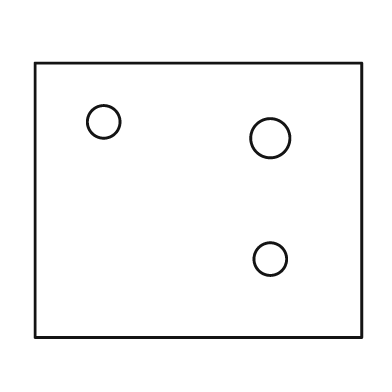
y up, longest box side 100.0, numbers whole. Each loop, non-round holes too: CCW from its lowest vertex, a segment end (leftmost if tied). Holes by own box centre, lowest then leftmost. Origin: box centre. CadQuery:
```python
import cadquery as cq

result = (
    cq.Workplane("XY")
    .moveTo(-50.0, -42.0)
    .lineTo(50.0, -42.0)
    .lineTo(50.0, 42.0)
    .lineTo(-50.0, 42.0)
    .close()
    .moveTo(22.0, -18.0)
    .circle(5.0)
    .moveTo(22.0, 19.0)
    .circle(6.0)
    .moveTo(-29.0, 24.0)
    .circle(5.0)
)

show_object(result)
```